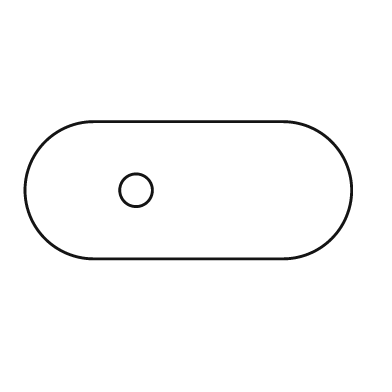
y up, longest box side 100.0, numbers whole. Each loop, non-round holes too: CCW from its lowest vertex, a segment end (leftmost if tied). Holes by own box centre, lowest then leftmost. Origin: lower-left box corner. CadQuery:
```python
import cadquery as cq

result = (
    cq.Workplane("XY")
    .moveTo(21.0, 0.0)
    .lineTo(79.0, 0.0)
    .threePointArc((100.0, 21.0), (79.0, 42.0))
    .lineTo(21.0, 42.0)
    .threePointArc((0.0, 21.0), (21.0, 0.0))
    .close()
    .moveTo(34.0, 21.0)
    .circle(5.0)
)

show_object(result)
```